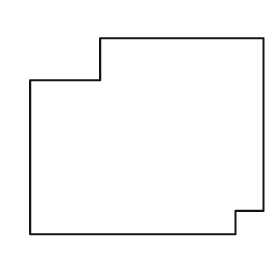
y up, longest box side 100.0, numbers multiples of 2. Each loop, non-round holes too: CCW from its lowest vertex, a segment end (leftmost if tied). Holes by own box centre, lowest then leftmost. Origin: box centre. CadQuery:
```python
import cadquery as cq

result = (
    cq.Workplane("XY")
    .moveTo(-50.0, -42.0)
    .lineTo(38.0, -42.0)
    .lineTo(38.0, -32.0)
    .lineTo(50.0, -32.0)
    .lineTo(50.0, 42.0)
    .lineTo(-20.0, 42.0)
    .lineTo(-20.0, 24.0)
    .lineTo(-50.0, 24.0)
    .close()
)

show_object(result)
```